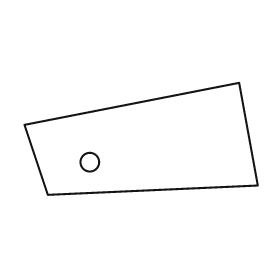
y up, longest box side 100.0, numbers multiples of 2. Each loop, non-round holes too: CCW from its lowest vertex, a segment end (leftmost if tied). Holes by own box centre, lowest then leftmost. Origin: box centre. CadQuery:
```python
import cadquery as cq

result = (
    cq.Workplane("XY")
    .moveTo(-40.0, -24.0)
    .lineTo(50.0, -20.0)
    .lineTo(42.0, 24.0)
    .lineTo(-50.0, 6.0)
    .close()
    .moveTo(-22.0, -10.0)
    .circle(4.0)
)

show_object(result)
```